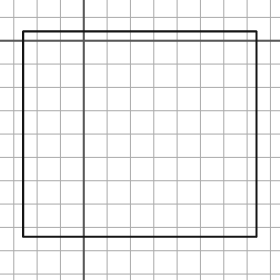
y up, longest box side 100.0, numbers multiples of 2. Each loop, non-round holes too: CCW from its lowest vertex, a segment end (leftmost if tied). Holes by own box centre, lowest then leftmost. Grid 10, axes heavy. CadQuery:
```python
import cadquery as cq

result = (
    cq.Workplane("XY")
    .moveTo(-26.0, -84.0)
    .lineTo(74.0, -84.0)
    .lineTo(74.0, 4.0)
    .lineTo(-26.0, 4.0)
    .close()
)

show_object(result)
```